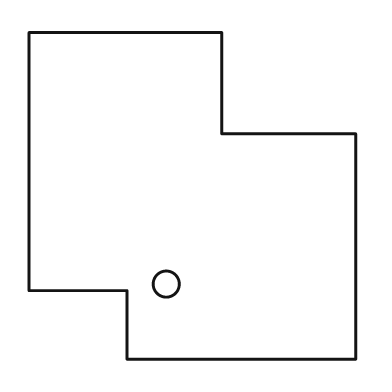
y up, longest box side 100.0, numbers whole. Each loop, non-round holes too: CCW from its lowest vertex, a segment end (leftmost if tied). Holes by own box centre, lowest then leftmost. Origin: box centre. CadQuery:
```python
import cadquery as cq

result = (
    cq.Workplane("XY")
    .moveTo(-20.0, -50.0)
    .lineTo(50.0, -50.0)
    .lineTo(50.0, 19.0)
    .lineTo(9.0, 19.0)
    .lineTo(9.0, 50.0)
    .lineTo(-50.0, 50.0)
    .lineTo(-50.0, -29.0)
    .lineTo(-20.0, -29.0)
    .close()
    .moveTo(-8.0, -27.0)
    .circle(4.0)
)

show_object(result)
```